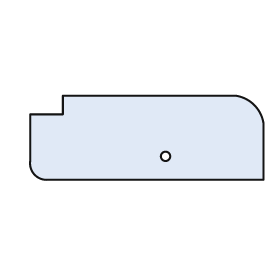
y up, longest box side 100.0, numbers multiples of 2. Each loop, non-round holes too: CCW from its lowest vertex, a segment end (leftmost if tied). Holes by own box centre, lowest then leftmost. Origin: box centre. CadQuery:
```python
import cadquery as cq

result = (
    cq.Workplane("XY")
    .moveTo(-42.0, -18.0)
    .lineTo(50.0, -18.0)
    .lineTo(50.0, 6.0)
    .threePointArc((46.0, 14.0), (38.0, 18.0))
    .lineTo(-36.0, 18.0)
    .lineTo(-36.0, 10.0)
    .lineTo(-50.0, 10.0)
    .lineTo(-50.0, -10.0)
    .threePointArc((-48.0, -16.0), (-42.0, -18.0))
    .close()
    .moveTo(8.0, -8.0)
    .circle(2.0)
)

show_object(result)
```